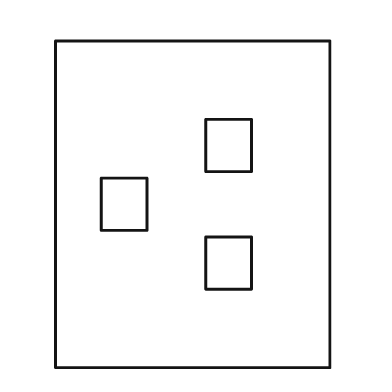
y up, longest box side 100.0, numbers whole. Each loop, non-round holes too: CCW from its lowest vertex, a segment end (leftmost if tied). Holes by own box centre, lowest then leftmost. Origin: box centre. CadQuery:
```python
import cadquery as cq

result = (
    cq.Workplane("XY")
    .moveTo(-42.0, -50.0)
    .lineTo(42.0, -50.0)
    .lineTo(42.0, 50.0)
    .lineTo(-42.0, 50.0)
    .close()
    .moveTo(4.0, -26.0)
    .lineTo(18.0, -26.0)
    .lineTo(18.0, -10.0)
    .lineTo(4.0, -10.0)
    .close()
    .moveTo(-28.0, -8.0)
    .lineTo(-14.0, -8.0)
    .lineTo(-14.0, 8.0)
    .lineTo(-28.0, 8.0)
    .close()
    .moveTo(4.0, 10.0)
    .lineTo(18.0, 10.0)
    .lineTo(18.0, 26.0)
    .lineTo(4.0, 26.0)
    .close()
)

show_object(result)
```